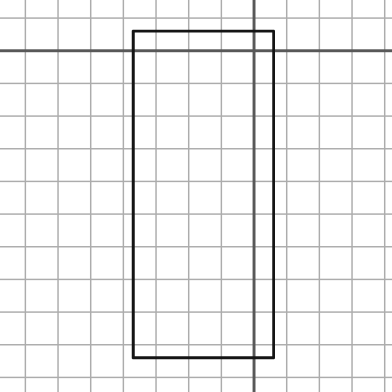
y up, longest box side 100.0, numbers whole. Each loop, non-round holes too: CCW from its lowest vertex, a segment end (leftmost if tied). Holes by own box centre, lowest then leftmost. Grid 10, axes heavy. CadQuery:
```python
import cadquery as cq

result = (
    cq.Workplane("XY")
    .moveTo(-37.0, -94.0)
    .lineTo(6.0, -94.0)
    .lineTo(6.0, 6.0)
    .lineTo(-37.0, 6.0)
    .close()
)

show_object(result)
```